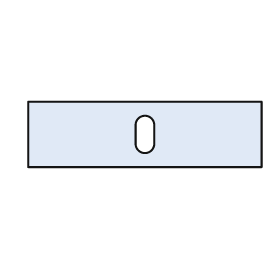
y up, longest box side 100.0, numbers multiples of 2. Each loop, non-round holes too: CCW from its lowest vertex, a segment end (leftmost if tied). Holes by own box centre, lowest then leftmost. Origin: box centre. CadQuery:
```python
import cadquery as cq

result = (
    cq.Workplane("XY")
    .moveTo(-50.0, -14.0)
    .lineTo(50.0, -14.0)
    .lineTo(50.0, 14.0)
    .lineTo(-50.0, 14.0)
    .close()
    .moveTo(-4.0, -4.0)
    .threePointArc((0.0, -8.0), (4.0, -4.0))
    .lineTo(4.0, 4.0)
    .threePointArc((0.0, 8.0), (-4.0, 4.0))
    .close()
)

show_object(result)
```